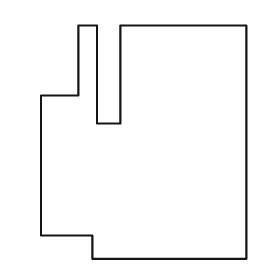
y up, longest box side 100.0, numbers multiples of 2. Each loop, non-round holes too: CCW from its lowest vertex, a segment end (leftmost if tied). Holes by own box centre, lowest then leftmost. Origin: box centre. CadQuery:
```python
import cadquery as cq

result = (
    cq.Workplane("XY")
    .moveTo(-22.0, -50.0)
    .lineTo(44.0, -50.0)
    .lineTo(44.0, 50.0)
    .lineTo(-10.0, 50.0)
    .lineTo(-10.0, 8.0)
    .lineTo(-20.0, 8.0)
    .lineTo(-20.0, 50.0)
    .lineTo(-28.0, 50.0)
    .lineTo(-28.0, 20.0)
    .lineTo(-44.0, 20.0)
    .lineTo(-44.0, -40.0)
    .lineTo(-22.0, -40.0)
    .close()
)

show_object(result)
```